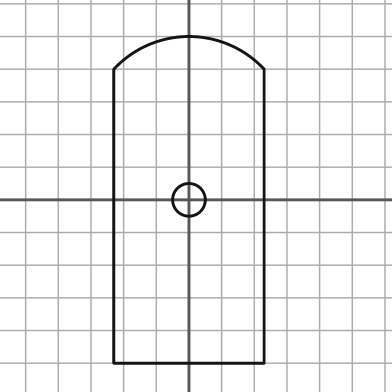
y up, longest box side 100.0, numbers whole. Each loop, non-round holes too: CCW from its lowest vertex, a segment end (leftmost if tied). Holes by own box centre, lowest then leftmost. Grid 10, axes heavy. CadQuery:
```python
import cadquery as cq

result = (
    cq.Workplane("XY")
    .moveTo(-23.0, -50.0)
    .lineTo(23.0, -50.0)
    .lineTo(23.0, 40.0)
    .threePointArc((0.0, 50.0), (-23.0, 40.0))
    .close()
    .moveTo(0.0, 0.0)
    .circle(5.0)
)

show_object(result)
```